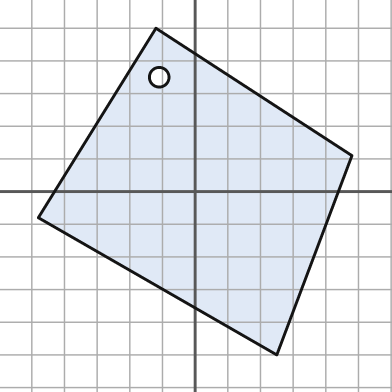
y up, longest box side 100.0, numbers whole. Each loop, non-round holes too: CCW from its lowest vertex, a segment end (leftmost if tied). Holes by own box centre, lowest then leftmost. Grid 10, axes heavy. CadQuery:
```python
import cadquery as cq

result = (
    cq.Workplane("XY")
    .moveTo(25.0, -50.0)
    .lineTo(48.0, 11.0)
    .lineTo(-12.0, 50.0)
    .lineTo(-48.0, -8.0)
    .close()
    .moveTo(-11.0, 35.0)
    .circle(3.0)
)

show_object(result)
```